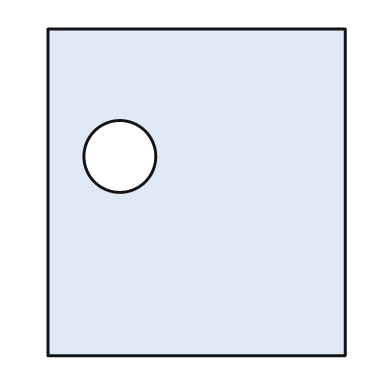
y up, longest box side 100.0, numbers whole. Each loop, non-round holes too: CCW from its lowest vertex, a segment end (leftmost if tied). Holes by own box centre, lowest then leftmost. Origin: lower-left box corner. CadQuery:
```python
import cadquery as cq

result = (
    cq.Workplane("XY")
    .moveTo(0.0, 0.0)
    .lineTo(91.0, 0.0)
    .lineTo(91.0, 100.0)
    .lineTo(0.0, 100.0)
    .close()
    .moveTo(22.0, 61.0)
    .circle(11.0)
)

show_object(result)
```